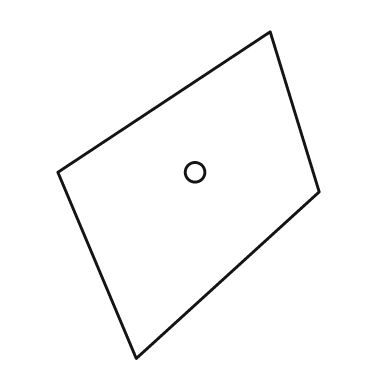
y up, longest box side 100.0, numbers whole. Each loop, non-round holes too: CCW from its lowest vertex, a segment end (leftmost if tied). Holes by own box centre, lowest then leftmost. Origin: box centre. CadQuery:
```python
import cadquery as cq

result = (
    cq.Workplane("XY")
    .moveTo(-16.0, -50.0)
    .lineTo(40.0, 1.0)
    .lineTo(25.0, 50.0)
    .lineTo(-40.0, 7.0)
    .close()
    .moveTo(2.0, 7.0)
    .circle(3.0)
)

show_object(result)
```